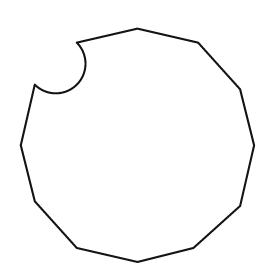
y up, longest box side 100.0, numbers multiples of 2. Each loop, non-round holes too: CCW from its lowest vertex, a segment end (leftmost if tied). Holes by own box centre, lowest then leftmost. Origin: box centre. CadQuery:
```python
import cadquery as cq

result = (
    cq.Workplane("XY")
    .moveTo(0.0, -50.0)
    .lineTo(24.0, -44.0)
    .lineTo(44.0, -26.0)
    .lineTo(50.0, 0.0)
    .lineTo(44.0, 24.0)
    .lineTo(26.0, 44.0)
    .lineTo(0.0, 50.0)
    .lineTo(-26.0, 44.0)
    .threePointArc((-26.0, 26.0), (-44.0, 26.0))
    .lineTo(-50.0, 0.0)
    .lineTo(-44.0, -24.0)
    .lineTo(-26.0, -44.0)
    .close()
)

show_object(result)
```